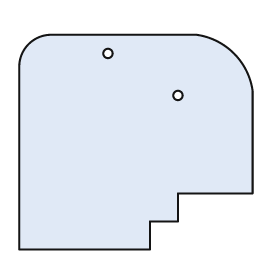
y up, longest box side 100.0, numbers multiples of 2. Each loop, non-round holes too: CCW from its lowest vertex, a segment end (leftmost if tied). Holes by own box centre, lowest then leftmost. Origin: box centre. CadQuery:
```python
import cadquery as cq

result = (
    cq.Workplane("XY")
    .moveTo(-50.0, -46.0)
    .lineTo(6.0, -46.0)
    .lineTo(6.0, -34.0)
    .lineTo(18.0, -34.0)
    .lineTo(18.0, -22.0)
    .lineTo(50.0, -22.0)
    .lineTo(50.0, 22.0)
    .threePointArc((42.0, 38.0), (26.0, 46.0))
    .lineTo(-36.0, 46.0)
    .threePointArc((-46.0, 42.0), (-50.0, 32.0))
    .close()
    .moveTo(18.0, 20.0)
    .circle(2.0)
    .moveTo(-12.0, 38.0)
    .circle(2.0)
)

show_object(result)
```